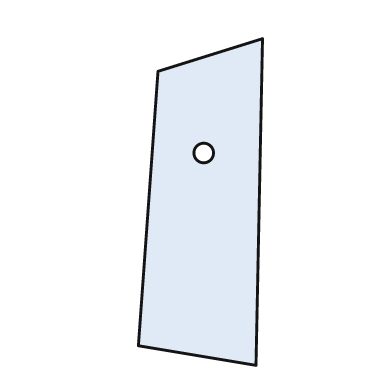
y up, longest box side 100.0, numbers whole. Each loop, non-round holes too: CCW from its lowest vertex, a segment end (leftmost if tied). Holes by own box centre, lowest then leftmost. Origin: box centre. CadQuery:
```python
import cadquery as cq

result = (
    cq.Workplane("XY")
    .moveTo(17.0, -50.0)
    .lineTo(19.0, 50.0)
    .lineTo(-13.0, 40.0)
    .lineTo(-19.0, -44.0)
    .close()
    .moveTo(1.0, 15.0)
    .circle(3.0)
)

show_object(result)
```